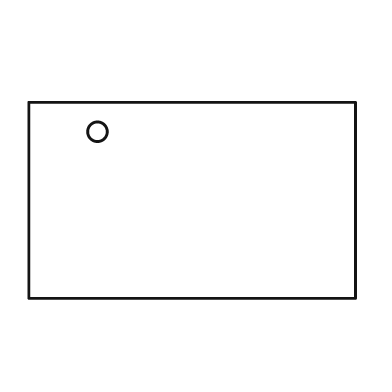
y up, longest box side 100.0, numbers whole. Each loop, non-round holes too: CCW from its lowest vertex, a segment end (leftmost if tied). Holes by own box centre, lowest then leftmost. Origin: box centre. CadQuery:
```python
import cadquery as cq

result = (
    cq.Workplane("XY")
    .moveTo(-50.0, -30.0)
    .lineTo(50.0, -30.0)
    .lineTo(50.0, 30.0)
    .lineTo(-50.0, 30.0)
    .close()
    .moveTo(-29.0, 21.0)
    .circle(3.0)
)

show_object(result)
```